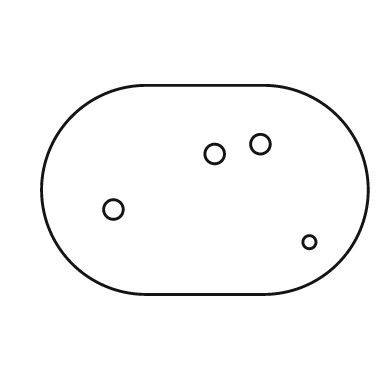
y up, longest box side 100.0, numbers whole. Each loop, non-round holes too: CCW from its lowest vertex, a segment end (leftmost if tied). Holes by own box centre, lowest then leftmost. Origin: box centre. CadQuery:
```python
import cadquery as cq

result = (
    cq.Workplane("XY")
    .moveTo(-18.0, -32.0)
    .lineTo(18.0, -32.0)
    .threePointArc((50.0, 0.0), (18.0, 32.0))
    .lineTo(-18.0, 32.0)
    .threePointArc((-50.0, 0.0), (-18.0, -32.0))
    .close()
    .moveTo(32.0, -16.0)
    .circle(2.0)
    .moveTo(-28.0, -6.0)
    .circle(3.0)
    .moveTo(3.0, 11.0)
    .circle(3.0)
    .moveTo(17.0, 14.0)
    .circle(3.0)
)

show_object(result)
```